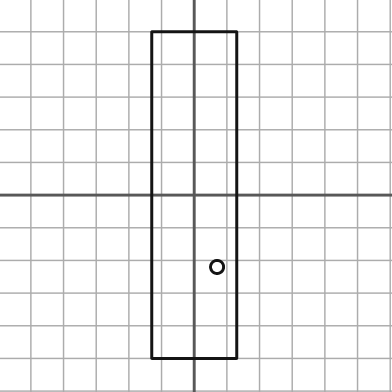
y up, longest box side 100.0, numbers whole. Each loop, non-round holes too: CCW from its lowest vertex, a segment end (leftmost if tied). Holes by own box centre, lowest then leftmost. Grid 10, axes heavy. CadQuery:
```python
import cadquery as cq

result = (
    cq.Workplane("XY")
    .moveTo(-13.0, -50.0)
    .lineTo(13.0, -50.0)
    .lineTo(13.0, 50.0)
    .lineTo(-13.0, 50.0)
    .close()
    .moveTo(7.0, -22.0)
    .circle(2.0)
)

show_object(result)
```